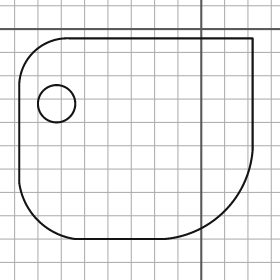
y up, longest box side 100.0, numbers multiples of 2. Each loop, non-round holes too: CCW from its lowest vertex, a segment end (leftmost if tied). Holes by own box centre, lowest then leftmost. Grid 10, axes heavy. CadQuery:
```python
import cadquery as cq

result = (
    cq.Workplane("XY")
    .moveTo(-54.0, -90.0)
    .lineTo(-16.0, -90.0)
    .threePointArc((10.0, -78.0), (22.0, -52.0))
    .lineTo(22.0, -4.0)
    .lineTo(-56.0, -4.0)
    .threePointArc((-72.0, -10.0), (-78.0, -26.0))
    .lineTo(-78.0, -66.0)
    .threePointArc((-70.0, -82.0), (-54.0, -90.0))
    .close()
    .moveTo(-62.0, -32.0)
    .circle(8.0)
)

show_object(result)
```